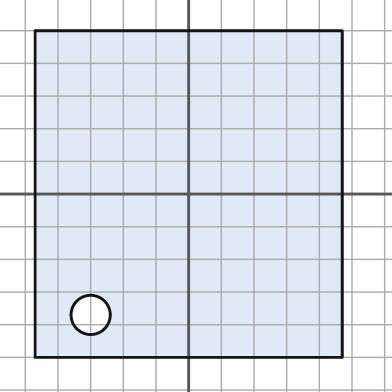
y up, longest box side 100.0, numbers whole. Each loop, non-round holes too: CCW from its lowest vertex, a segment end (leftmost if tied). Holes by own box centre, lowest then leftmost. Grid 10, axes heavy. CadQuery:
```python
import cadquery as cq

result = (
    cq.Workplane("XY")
    .moveTo(-47.0, -50.0)
    .lineTo(47.0, -50.0)
    .lineTo(47.0, 50.0)
    .lineTo(-47.0, 50.0)
    .close()
    .moveTo(-30.0, -37.0)
    .circle(6.0)
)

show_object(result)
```